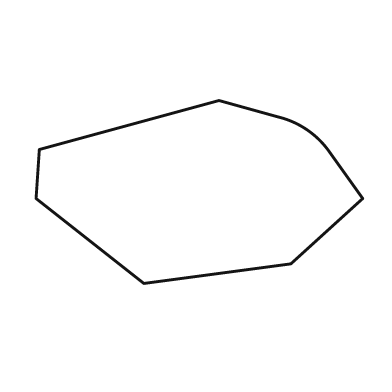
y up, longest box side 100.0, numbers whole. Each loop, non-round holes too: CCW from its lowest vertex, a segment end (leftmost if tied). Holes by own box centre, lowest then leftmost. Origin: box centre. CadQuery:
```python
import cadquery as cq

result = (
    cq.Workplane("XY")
    .moveTo(-17.0, -28.0)
    .lineTo(28.0, -22.0)
    .lineTo(50.0, -2.0)
    .lineTo(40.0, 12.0)
    .threePointArc((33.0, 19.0), (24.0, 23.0))
    .lineTo(6.0, 28.0)
    .lineTo(-49.0, 13.0)
    .lineTo(-50.0, -2.0)
    .close()
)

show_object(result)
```